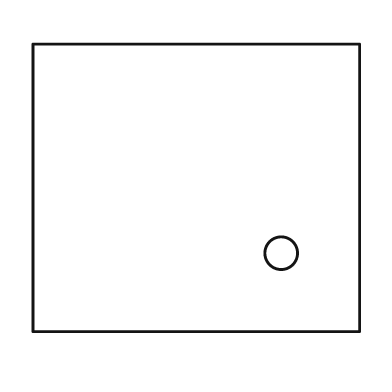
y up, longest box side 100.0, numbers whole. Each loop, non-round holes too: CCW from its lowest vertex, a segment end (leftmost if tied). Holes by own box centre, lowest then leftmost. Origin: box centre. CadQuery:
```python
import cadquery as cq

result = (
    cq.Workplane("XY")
    .moveTo(-50.0, -44.0)
    .lineTo(50.0, -44.0)
    .lineTo(50.0, 44.0)
    .lineTo(-50.0, 44.0)
    .close()
    .moveTo(26.0, -20.0)
    .circle(5.0)
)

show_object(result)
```